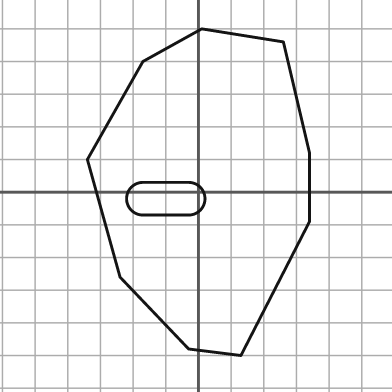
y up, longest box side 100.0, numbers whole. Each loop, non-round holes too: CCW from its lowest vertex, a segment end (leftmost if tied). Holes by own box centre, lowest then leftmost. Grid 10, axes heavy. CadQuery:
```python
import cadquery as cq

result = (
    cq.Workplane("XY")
    .moveTo(13.0, -50.0)
    .lineTo(34.0, -9.0)
    .lineTo(34.0, 12.0)
    .lineTo(26.0, 46.0)
    .lineTo(1.0, 50.0)
    .lineTo(-17.0, 40.0)
    .lineTo(-34.0, 10.0)
    .lineTo(-24.0, -26.0)
    .lineTo(-3.0, -48.0)
    .close()
    .moveTo(-17.0, -7.0)
    .lineTo(-3.0, -7.0)
    .threePointArc((2.0, -2.0), (-3.0, 3.0))
    .lineTo(-17.0, 3.0)
    .threePointArc((-22.0, -2.0), (-17.0, -7.0))
    .close()
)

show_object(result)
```